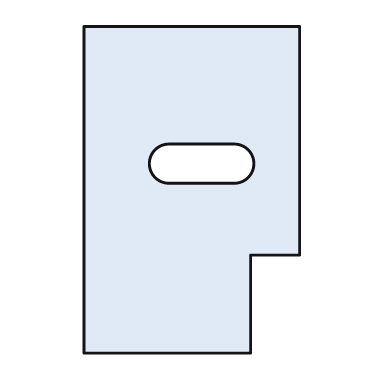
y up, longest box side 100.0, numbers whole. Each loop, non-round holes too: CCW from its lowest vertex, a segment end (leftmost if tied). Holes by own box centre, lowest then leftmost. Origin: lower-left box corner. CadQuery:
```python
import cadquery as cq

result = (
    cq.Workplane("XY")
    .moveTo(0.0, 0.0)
    .lineTo(51.0, 0.0)
    .lineTo(51.0, 30.0)
    .lineTo(66.0, 30.0)
    .lineTo(66.0, 100.0)
    .lineTo(0.0, 100.0)
    .close()
    .moveTo(26.0, 52.0)
    .lineTo(46.0, 52.0)
    .threePointArc((52.0, 58.0), (46.0, 64.0))
    .lineTo(26.0, 64.0)
    .threePointArc((20.0, 58.0), (26.0, 52.0))
    .close()
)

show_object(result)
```